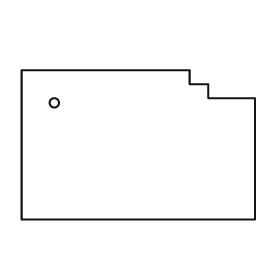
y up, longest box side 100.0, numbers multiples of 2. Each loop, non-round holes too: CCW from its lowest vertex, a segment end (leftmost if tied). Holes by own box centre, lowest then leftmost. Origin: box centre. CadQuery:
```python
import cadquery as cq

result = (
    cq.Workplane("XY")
    .moveTo(-50.0, -32.0)
    .lineTo(50.0, -32.0)
    .lineTo(50.0, 20.0)
    .lineTo(30.0, 20.0)
    .lineTo(30.0, 26.0)
    .lineTo(22.0, 26.0)
    .lineTo(22.0, 32.0)
    .lineTo(-50.0, 32.0)
    .close()
    .moveTo(-36.0, 18.0)
    .circle(2.0)
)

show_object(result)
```